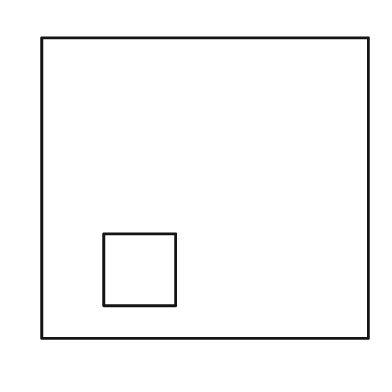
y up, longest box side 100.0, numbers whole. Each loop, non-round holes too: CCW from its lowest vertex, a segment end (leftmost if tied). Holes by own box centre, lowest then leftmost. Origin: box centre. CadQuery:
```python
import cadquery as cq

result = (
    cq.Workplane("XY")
    .moveTo(-50.0, -46.0)
    .lineTo(50.0, -46.0)
    .lineTo(50.0, 46.0)
    .lineTo(-50.0, 46.0)
    .close()
    .moveTo(-31.0, -36.0)
    .lineTo(-9.0, -36.0)
    .lineTo(-9.0, -14.0)
    .lineTo(-31.0, -14.0)
    .close()
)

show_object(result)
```